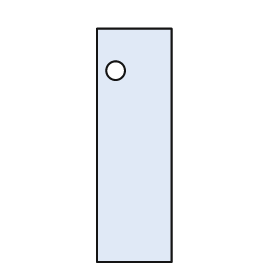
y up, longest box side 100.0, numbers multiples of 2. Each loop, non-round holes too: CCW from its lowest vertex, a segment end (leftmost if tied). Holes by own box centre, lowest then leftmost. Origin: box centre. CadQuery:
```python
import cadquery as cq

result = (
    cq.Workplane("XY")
    .moveTo(-16.0, -50.0)
    .lineTo(16.0, -50.0)
    .lineTo(16.0, 50.0)
    .lineTo(-16.0, 50.0)
    .close()
    .moveTo(-8.0, 32.0)
    .circle(4.0)
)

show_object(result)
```